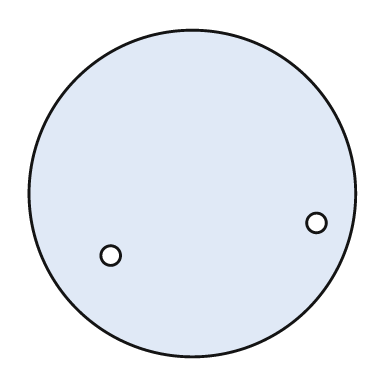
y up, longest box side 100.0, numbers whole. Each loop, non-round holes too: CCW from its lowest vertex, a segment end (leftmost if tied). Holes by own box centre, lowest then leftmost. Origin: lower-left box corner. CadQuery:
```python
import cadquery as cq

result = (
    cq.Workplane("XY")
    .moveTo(50.0, 50.0)
    .circle(50.0)
    .moveTo(25.0, 31.0)
    .circle(3.0)
    .moveTo(88.0, 41.0)
    .circle(3.0)
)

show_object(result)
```